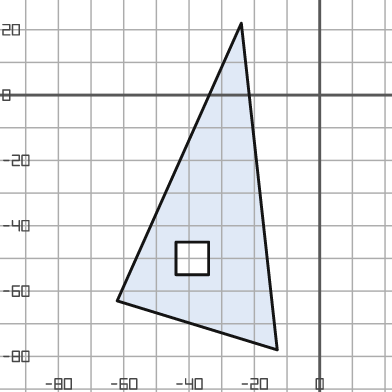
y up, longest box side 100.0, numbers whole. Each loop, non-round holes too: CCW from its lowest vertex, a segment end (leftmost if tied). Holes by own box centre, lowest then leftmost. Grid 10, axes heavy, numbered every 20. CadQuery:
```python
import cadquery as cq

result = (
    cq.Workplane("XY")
    .moveTo(-13.0, -78.0)
    .lineTo(-24.0, 22.0)
    .lineTo(-62.0, -63.0)
    .close()
    .moveTo(-44.0, -55.0)
    .lineTo(-34.0, -55.0)
    .lineTo(-34.0, -45.0)
    .lineTo(-44.0, -45.0)
    .close()
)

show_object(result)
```